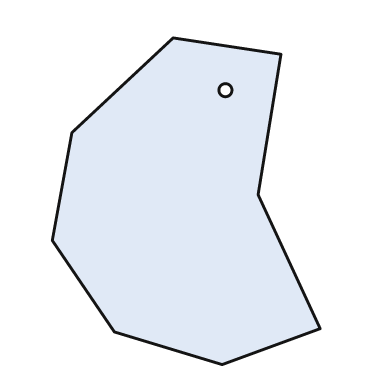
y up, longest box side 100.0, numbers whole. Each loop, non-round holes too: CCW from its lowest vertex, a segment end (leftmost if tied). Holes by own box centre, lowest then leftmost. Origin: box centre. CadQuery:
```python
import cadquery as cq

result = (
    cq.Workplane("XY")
    .moveTo(11.0, -50.0)
    .lineTo(41.0, -39.0)
    .lineTo(22.0, 2.0)
    .lineTo(29.0, 45.0)
    .lineTo(-4.0, 50.0)
    .lineTo(-35.0, 21.0)
    .lineTo(-41.0, -12.0)
    .lineTo(-22.0, -40.0)
    .close()
    .moveTo(12.0, 34.0)
    .circle(2.0)
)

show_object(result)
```